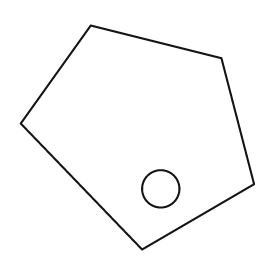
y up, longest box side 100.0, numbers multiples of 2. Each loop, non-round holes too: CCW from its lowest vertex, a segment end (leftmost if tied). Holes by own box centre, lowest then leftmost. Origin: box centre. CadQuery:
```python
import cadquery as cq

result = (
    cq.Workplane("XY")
    .moveTo(2.0, -48.0)
    .lineTo(50.0, -20.0)
    .lineTo(36.0, 34.0)
    .lineTo(-20.0, 48.0)
    .lineTo(-50.0, 6.0)
    .close()
    .moveTo(10.0, -22.0)
    .circle(8.0)
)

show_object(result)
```